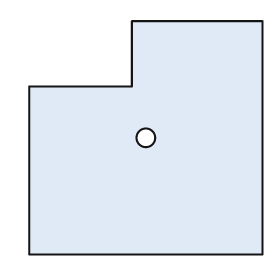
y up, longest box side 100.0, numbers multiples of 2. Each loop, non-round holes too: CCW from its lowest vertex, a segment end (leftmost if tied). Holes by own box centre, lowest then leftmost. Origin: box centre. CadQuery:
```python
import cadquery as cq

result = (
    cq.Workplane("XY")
    .moveTo(-50.0, -50.0)
    .lineTo(50.0, -50.0)
    .lineTo(50.0, 50.0)
    .lineTo(-6.0, 50.0)
    .lineTo(-6.0, 22.0)
    .lineTo(-50.0, 22.0)
    .close()
    .moveTo(0.0, 0.0)
    .circle(4.0)
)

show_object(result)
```